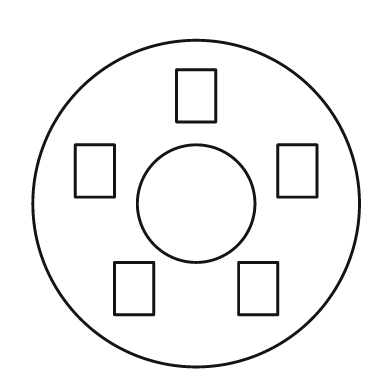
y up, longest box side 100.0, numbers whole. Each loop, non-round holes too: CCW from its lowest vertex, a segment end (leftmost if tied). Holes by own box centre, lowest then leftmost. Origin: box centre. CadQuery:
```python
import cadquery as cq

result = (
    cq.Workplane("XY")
    .moveTo(0.0, 0.0)
    .circle(50.0)
    .moveTo(-25.0, -34.0)
    .lineTo(-13.0, -34.0)
    .lineTo(-13.0, -18.0)
    .lineTo(-25.0, -18.0)
    .close()
    .moveTo(13.0, -34.0)
    .lineTo(25.0, -34.0)
    .lineTo(25.0, -18.0)
    .lineTo(13.0, -18.0)
    .close()
    .moveTo(0.0, 0.0)
    .circle(18.0)
    .moveTo(-37.0, 2.0)
    .lineTo(-25.0, 2.0)
    .lineTo(-25.0, 18.0)
    .lineTo(-37.0, 18.0)
    .close()
    .moveTo(25.0, 2.0)
    .lineTo(37.0, 2.0)
    .lineTo(37.0, 18.0)
    .lineTo(25.0, 18.0)
    .close()
    .moveTo(-6.0, 25.0)
    .lineTo(6.0, 25.0)
    .lineTo(6.0, 41.0)
    .lineTo(-6.0, 41.0)
    .close()
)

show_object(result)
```